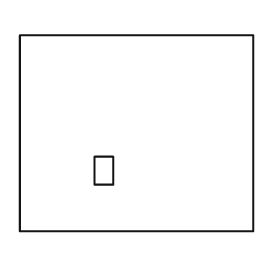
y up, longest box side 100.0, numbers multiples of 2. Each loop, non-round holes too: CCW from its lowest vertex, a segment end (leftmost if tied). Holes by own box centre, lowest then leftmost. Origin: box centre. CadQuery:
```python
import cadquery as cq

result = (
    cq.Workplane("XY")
    .moveTo(-50.0, -42.0)
    .lineTo(50.0, -42.0)
    .lineTo(50.0, 42.0)
    .lineTo(-50.0, 42.0)
    .close()
    .moveTo(-18.0, -22.0)
    .lineTo(-10.0, -22.0)
    .lineTo(-10.0, -10.0)
    .lineTo(-18.0, -10.0)
    .close()
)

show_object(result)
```